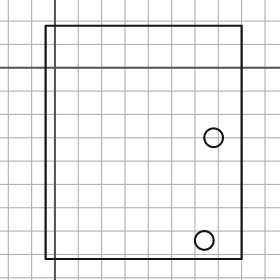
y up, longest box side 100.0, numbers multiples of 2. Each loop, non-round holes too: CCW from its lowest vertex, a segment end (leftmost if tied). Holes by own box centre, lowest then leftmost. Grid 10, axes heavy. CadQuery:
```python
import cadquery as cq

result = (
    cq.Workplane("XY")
    .moveTo(-4.0, -82.0)
    .lineTo(80.0, -82.0)
    .lineTo(80.0, 18.0)
    .lineTo(-4.0, 18.0)
    .close()
    .moveTo(64.0, -74.0)
    .circle(4.0)
    .moveTo(68.0, -30.0)
    .circle(4.0)
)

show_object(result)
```